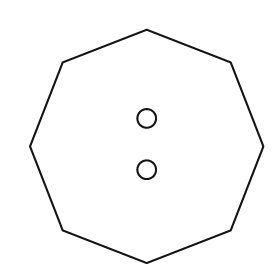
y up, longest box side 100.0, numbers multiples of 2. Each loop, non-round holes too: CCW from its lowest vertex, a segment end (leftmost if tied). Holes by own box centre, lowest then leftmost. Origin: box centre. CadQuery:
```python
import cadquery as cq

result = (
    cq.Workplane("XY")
    .moveTo(0.0, -50.0)
    .lineTo(36.0, -36.0)
    .lineTo(50.0, 0.0)
    .lineTo(36.0, 36.0)
    .lineTo(0.0, 50.0)
    .lineTo(-36.0, 36.0)
    .lineTo(-50.0, 0.0)
    .lineTo(-36.0, -36.0)
    .close()
    .moveTo(0.0, -10.0)
    .circle(4.0)
    .moveTo(0.0, 12.0)
    .circle(4.0)
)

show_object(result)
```